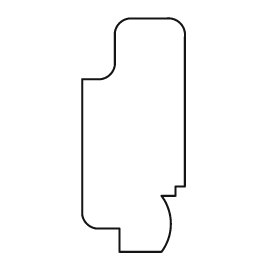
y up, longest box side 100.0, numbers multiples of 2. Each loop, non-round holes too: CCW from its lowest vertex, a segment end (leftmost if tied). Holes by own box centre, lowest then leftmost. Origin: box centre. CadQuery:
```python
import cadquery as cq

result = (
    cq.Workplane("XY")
    .moveTo(-6.0, -50.0)
    .lineTo(12.0, -50.0)
    .threePointArc((16.0, -38.0), (12.0, -26.0))
    .lineTo(18.0, -26.0)
    .lineTo(18.0, -22.0)
    .lineTo(22.0, -22.0)
    .lineTo(22.0, 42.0)
    .threePointArc((20.0, 48.0), (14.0, 50.0))
    .lineTo(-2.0, 50.0)
    .threePointArc((-6.0, 48.0), (-8.0, 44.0))
    .lineTo(-8.0, 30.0)
    .threePointArc((-10.0, 26.0), (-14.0, 24.0))
    .lineTo(-22.0, 24.0)
    .lineTo(-22.0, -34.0)
    .threePointArc((-20.0, -38.0), (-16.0, -40.0))
    .lineTo(-6.0, -40.0)
    .close()
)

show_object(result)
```